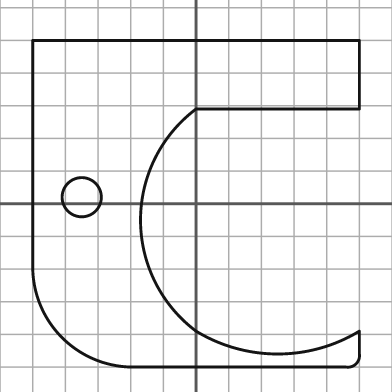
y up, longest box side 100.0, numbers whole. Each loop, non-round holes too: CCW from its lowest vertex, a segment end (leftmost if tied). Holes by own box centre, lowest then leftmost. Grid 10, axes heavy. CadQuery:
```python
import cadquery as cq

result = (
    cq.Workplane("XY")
    .moveTo(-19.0, -50.0)
    .lineTo(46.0, -50.0)
    .threePointArc((49.0, -49.0), (50.0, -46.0))
    .lineTo(50.0, -39.0)
    .threePointArc((25.0, -46.0), (0.0, -39.0))
    .threePointArc((-17.0, -5.0), (0.0, 29.0))
    .lineTo(50.0, 29.0)
    .lineTo(50.0, 50.0)
    .lineTo(-50.0, 50.0)
    .lineTo(-50.0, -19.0)
    .threePointArc((-41.0, -41.0), (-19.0, -50.0))
    .close()
    .moveTo(-35.0, 2.0)
    .circle(6.0)
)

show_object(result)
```